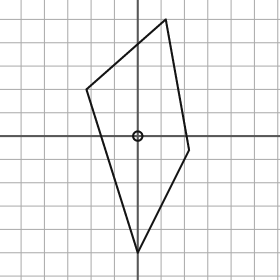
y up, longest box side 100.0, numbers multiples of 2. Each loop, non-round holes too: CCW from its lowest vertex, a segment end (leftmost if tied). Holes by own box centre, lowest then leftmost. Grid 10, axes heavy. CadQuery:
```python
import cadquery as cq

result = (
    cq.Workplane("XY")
    .moveTo(0.0, -50.0)
    .lineTo(22.0, -6.0)
    .lineTo(12.0, 50.0)
    .lineTo(-22.0, 20.0)
    .close()
    .moveTo(0.0, 0.0)
    .circle(2.0)
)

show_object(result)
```